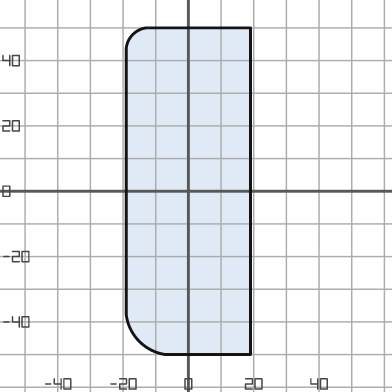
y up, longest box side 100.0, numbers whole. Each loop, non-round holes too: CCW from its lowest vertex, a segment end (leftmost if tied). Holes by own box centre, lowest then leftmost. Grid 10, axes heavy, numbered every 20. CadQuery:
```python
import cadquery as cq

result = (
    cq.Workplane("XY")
    .moveTo(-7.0, -50.0)
    .lineTo(19.0, -50.0)
    .lineTo(19.0, 50.0)
    .lineTo(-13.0, 50.0)
    .threePointArc((-17.0, 48.0), (-19.0, 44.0))
    .lineTo(-19.0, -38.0)
    .threePointArc((-15.0, -46.0), (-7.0, -50.0))
    .close()
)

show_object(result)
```